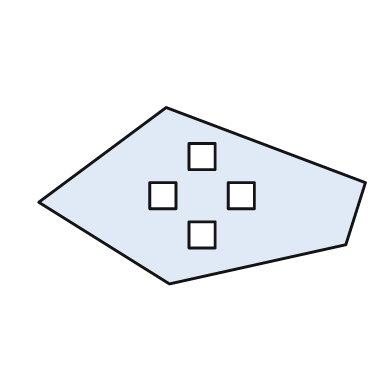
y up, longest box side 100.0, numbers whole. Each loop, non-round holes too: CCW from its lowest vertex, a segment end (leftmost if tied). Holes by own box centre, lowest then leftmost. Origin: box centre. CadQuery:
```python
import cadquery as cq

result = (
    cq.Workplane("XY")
    .moveTo(-10.0, -27.0)
    .lineTo(44.0, -15.0)
    .lineTo(50.0, 4.0)
    .lineTo(-11.0, 27.0)
    .lineTo(-50.0, -2.0)
    .close()
    .moveTo(-4.0, -16.0)
    .lineTo(4.0, -16.0)
    .lineTo(4.0, -8.0)
    .lineTo(-4.0, -8.0)
    .close()
    .moveTo(-16.0, -4.0)
    .lineTo(-8.0, -4.0)
    .lineTo(-8.0, 4.0)
    .lineTo(-16.0, 4.0)
    .close()
    .moveTo(8.0, -4.0)
    .lineTo(16.0, -4.0)
    .lineTo(16.0, 4.0)
    .lineTo(8.0, 4.0)
    .close()
    .moveTo(-4.0, 8.0)
    .lineTo(4.0, 8.0)
    .lineTo(4.0, 16.0)
    .lineTo(-4.0, 16.0)
    .close()
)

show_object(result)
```